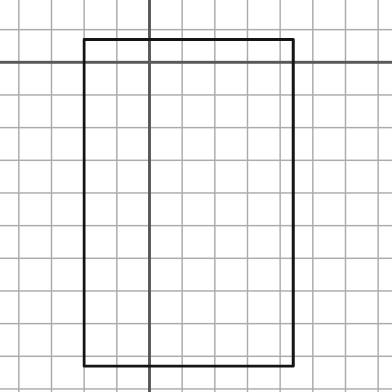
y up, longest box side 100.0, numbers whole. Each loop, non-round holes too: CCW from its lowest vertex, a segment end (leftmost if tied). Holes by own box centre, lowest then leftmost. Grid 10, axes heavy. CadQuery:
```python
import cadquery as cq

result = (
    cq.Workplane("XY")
    .moveTo(-20.0, -93.0)
    .lineTo(44.0, -93.0)
    .lineTo(44.0, 7.0)
    .lineTo(-20.0, 7.0)
    .close()
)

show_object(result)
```